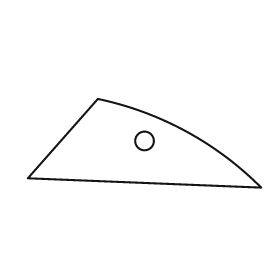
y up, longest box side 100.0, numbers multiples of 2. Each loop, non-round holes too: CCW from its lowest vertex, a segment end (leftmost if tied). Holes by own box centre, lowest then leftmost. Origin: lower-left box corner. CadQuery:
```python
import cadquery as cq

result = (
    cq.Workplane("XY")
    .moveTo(100.0, 0.0)
    .threePointArc((68.0, 24.0), (30.0, 38.0))
    .lineTo(0.0, 4.0)
    .close()
    .moveTo(50.0, 20.0)
    .circle(4.0)
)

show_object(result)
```